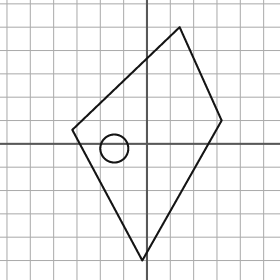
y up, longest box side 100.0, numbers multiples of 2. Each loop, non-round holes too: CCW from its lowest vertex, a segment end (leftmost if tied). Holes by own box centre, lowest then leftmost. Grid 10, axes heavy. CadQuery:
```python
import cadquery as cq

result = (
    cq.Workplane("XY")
    .moveTo(-2.0, -50.0)
    .lineTo(32.0, 10.0)
    .lineTo(14.0, 50.0)
    .lineTo(-32.0, 6.0)
    .close()
    .moveTo(-14.0, -2.0)
    .circle(6.0)
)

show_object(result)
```